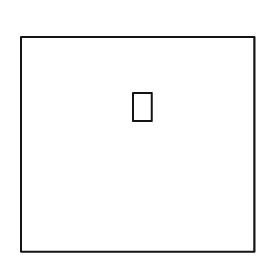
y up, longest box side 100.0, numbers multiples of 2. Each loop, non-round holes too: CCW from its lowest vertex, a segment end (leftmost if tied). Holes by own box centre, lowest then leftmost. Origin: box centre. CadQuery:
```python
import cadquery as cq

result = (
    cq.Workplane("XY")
    .moveTo(-50.0, -46.0)
    .lineTo(50.0, -46.0)
    .lineTo(50.0, 46.0)
    .lineTo(-50.0, 46.0)
    .close()
    .moveTo(-2.0, 10.0)
    .lineTo(6.0, 10.0)
    .lineTo(6.0, 22.0)
    .lineTo(-2.0, 22.0)
    .close()
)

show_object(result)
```